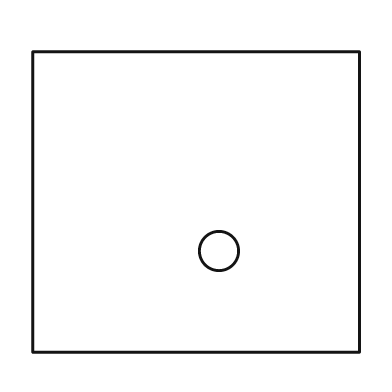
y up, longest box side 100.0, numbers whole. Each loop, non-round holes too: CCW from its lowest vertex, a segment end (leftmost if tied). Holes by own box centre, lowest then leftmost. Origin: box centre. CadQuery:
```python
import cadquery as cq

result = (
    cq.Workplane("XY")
    .moveTo(-50.0, -46.0)
    .lineTo(50.0, -46.0)
    .lineTo(50.0, 46.0)
    .lineTo(-50.0, 46.0)
    .close()
    .moveTo(7.0, -15.0)
    .circle(6.0)
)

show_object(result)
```